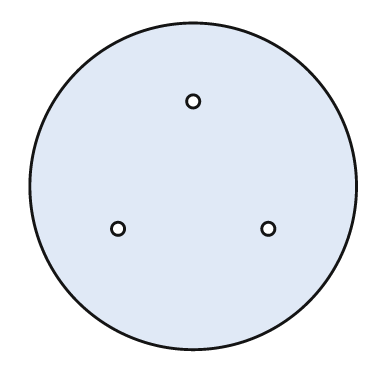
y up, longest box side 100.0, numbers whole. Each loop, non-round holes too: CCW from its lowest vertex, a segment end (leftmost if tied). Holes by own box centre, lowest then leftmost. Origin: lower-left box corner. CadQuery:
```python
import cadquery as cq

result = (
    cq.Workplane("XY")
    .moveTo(50.0, 50.0)
    .circle(50.0)
    .moveTo(27.0, 37.0)
    .circle(2.0)
    .moveTo(73.0, 37.0)
    .circle(2.0)
    .moveTo(50.0, 76.0)
    .circle(2.0)
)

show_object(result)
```